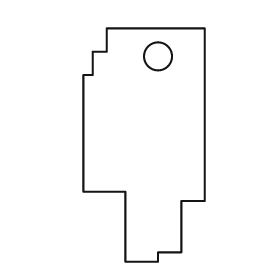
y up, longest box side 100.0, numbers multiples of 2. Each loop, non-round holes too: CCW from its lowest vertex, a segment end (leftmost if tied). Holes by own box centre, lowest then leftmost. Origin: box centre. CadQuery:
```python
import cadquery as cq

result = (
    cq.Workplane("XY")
    .moveTo(-8.0, -50.0)
    .lineTo(6.0, -50.0)
    .lineTo(6.0, -46.0)
    .lineTo(16.0, -46.0)
    .lineTo(16.0, -24.0)
    .lineTo(26.0, -24.0)
    .lineTo(26.0, 50.0)
    .lineTo(-16.0, 50.0)
    .lineTo(-16.0, 40.0)
    .lineTo(-22.0, 40.0)
    .lineTo(-22.0, 30.0)
    .lineTo(-26.0, 30.0)
    .lineTo(-26.0, -20.0)
    .lineTo(-8.0, -20.0)
    .close()
    .moveTo(6.0, 38.0)
    .circle(6.0)
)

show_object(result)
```